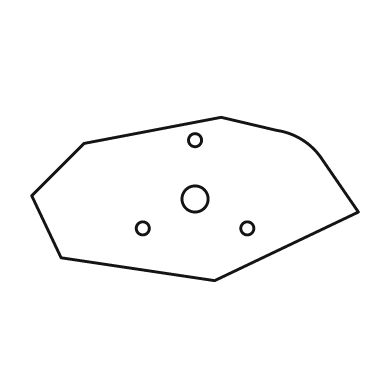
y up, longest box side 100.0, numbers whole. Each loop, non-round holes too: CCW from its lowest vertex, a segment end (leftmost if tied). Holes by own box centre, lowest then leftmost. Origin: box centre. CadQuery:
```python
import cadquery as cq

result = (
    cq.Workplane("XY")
    .moveTo(6.0, -25.0)
    .lineTo(50.0, -4.0)
    .lineTo(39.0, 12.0)
    .threePointArc((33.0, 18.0), (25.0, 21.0))
    .lineTo(8.0, 25.0)
    .lineTo(-34.0, 17.0)
    .lineTo(-50.0, 1.0)
    .lineTo(-41.0, -18.0)
    .close()
    .moveTo(-16.0, -9.0)
    .circle(2.0)
    .moveTo(16.0, -9.0)
    .circle(2.0)
    .moveTo(0.0, 0.0)
    .circle(4.0)
    .moveTo(0.0, 18.0)
    .circle(2.0)
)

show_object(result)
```